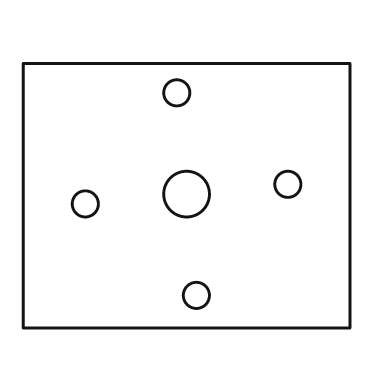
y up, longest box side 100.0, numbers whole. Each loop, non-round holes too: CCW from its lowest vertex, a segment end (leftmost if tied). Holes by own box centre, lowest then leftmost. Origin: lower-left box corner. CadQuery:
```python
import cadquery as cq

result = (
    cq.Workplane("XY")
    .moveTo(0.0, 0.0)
    .lineTo(100.0, 0.0)
    .lineTo(100.0, 81.0)
    .lineTo(0.0, 81.0)
    .close()
    .moveTo(53.0, 10.0)
    .circle(4.0)
    .moveTo(19.0, 38.0)
    .circle(4.0)
    .moveTo(50.0, 41.0)
    .circle(7.0)
    .moveTo(81.0, 44.0)
    .circle(4.0)
    .moveTo(47.0, 72.0)
    .circle(4.0)
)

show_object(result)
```